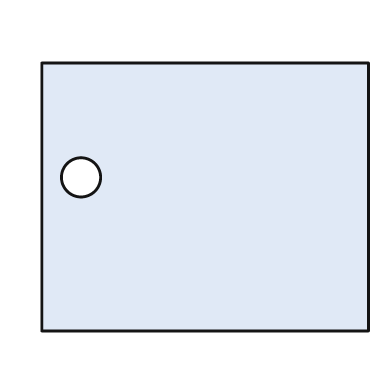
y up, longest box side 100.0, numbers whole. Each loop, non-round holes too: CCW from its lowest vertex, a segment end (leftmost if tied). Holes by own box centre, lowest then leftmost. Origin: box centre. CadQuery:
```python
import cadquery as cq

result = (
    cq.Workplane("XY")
    .moveTo(-50.0, -41.0)
    .lineTo(50.0, -41.0)
    .lineTo(50.0, 41.0)
    .lineTo(-50.0, 41.0)
    .close()
    .moveTo(-38.0, 6.0)
    .circle(6.0)
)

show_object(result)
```